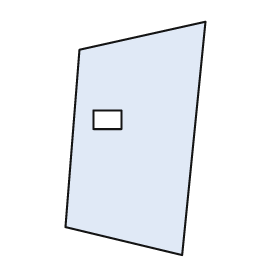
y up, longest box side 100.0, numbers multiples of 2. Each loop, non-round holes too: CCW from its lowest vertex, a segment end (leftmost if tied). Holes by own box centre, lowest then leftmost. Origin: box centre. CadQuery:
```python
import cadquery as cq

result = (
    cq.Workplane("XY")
    .moveTo(20.0, -50.0)
    .lineTo(30.0, 50.0)
    .lineTo(-24.0, 38.0)
    .lineTo(-30.0, -38.0)
    .close()
    .moveTo(-18.0, 4.0)
    .lineTo(-6.0, 4.0)
    .lineTo(-6.0, 12.0)
    .lineTo(-18.0, 12.0)
    .close()
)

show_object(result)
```